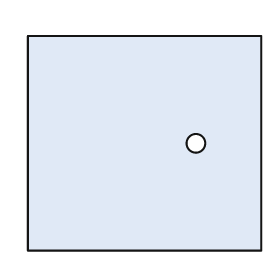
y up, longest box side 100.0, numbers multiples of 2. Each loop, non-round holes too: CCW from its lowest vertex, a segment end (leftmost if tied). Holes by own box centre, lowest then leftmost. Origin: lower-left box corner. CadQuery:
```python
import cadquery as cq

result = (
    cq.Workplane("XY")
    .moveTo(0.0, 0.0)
    .lineTo(100.0, 0.0)
    .lineTo(100.0, 92.0)
    .lineTo(0.0, 92.0)
    .close()
    .moveTo(72.0, 46.0)
    .circle(4.0)
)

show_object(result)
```